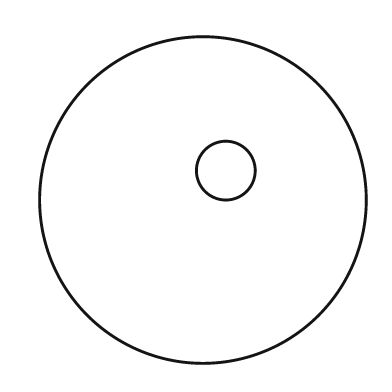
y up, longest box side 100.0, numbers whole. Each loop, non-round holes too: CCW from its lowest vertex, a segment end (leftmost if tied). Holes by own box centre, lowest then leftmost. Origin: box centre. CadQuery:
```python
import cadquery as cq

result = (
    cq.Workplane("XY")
    .moveTo(0.0, 0.0)
    .circle(50.0)
    .moveTo(7.0, 9.0)
    .circle(9.0)
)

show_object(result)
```